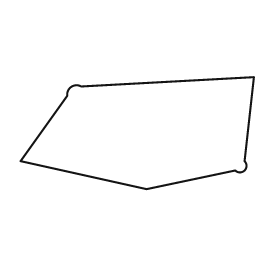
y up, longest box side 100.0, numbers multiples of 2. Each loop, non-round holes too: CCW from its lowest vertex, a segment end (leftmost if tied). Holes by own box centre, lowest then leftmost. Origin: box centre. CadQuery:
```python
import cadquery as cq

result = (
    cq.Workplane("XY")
    .moveTo(4.0, -24.0)
    .lineTo(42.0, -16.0)
    .threePointArc((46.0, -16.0), (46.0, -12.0))
    .lineTo(50.0, 24.0)
    .lineTo(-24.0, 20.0)
    .threePointArc((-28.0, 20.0), (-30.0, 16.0))
    .lineTo(-50.0, -12.0)
    .close()
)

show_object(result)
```